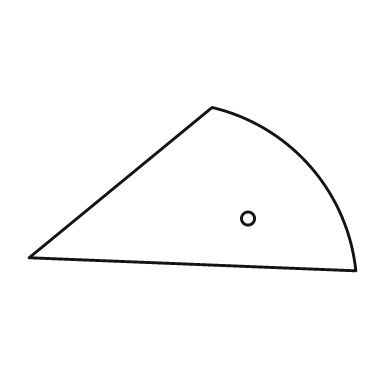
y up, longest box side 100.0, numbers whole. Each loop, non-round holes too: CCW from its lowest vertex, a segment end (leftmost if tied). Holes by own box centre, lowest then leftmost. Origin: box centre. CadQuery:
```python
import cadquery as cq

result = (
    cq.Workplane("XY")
    .moveTo(50.0, -25.0)
    .threePointArc((36.0, 7.0), (6.0, 25.0))
    .lineTo(-50.0, -21.0)
    .close()
    .moveTo(17.0, -9.0)
    .circle(2.0)
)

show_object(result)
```